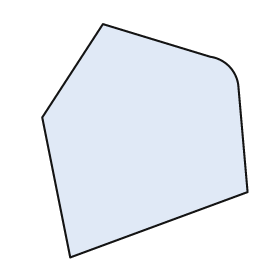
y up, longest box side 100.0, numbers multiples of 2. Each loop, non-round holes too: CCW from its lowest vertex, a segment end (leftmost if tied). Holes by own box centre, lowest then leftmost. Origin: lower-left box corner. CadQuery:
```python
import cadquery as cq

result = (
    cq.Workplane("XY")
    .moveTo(12.0, 0.0)
    .lineTo(88.0, 28.0)
    .lineTo(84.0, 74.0)
    .threePointArc((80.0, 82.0), (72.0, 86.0))
    .lineTo(26.0, 100.0)
    .lineTo(0.0, 60.0)
    .close()
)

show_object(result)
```